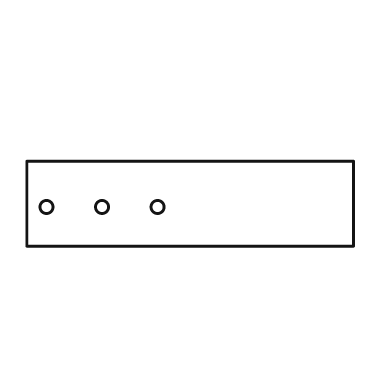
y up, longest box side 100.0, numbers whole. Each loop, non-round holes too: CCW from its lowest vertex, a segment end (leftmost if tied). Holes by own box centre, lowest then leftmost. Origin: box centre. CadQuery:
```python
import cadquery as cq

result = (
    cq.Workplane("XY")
    .moveTo(-50.0, -13.0)
    .lineTo(50.0, -13.0)
    .lineTo(50.0, 13.0)
    .lineTo(-50.0, 13.0)
    .close()
    .moveTo(-44.0, -1.0)
    .circle(2.0)
    .moveTo(-27.0, -1.0)
    .circle(2.0)
    .moveTo(-10.0, -1.0)
    .circle(2.0)
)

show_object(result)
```